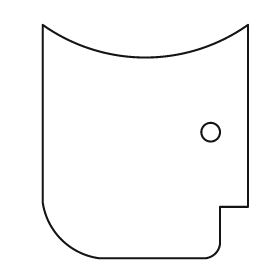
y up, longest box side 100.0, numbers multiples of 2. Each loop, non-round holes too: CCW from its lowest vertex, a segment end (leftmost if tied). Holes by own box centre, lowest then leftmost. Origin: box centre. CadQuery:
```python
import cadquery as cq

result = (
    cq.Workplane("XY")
    .moveTo(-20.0, -50.0)
    .lineTo(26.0, -50.0)
    .threePointArc((30.0, -48.0), (32.0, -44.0))
    .lineTo(32.0, -28.0)
    .lineTo(44.0, -28.0)
    .lineTo(44.0, 50.0)
    .threePointArc((0.0, 36.0), (-44.0, 50.0))
    .lineTo(-44.0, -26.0)
    .threePointArc((-36.0, -42.0), (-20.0, -50.0))
    .close()
    .moveTo(28.0, 4.0)
    .circle(4.0)
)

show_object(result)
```